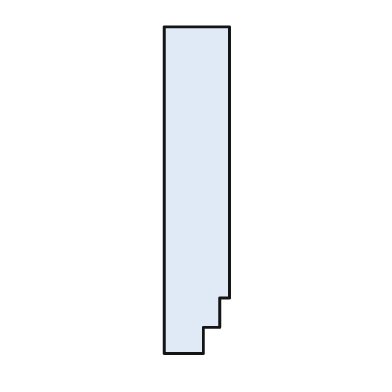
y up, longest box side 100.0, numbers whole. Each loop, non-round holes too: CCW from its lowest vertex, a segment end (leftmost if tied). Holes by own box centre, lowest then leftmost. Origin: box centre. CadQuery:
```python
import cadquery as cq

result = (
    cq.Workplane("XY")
    .moveTo(-10.0, -50.0)
    .lineTo(2.0, -50.0)
    .lineTo(2.0, -42.0)
    .lineTo(7.0, -42.0)
    .lineTo(7.0, -33.0)
    .lineTo(10.0, -33.0)
    .lineTo(10.0, 50.0)
    .lineTo(-10.0, 50.0)
    .close()
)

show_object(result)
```